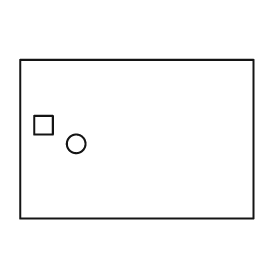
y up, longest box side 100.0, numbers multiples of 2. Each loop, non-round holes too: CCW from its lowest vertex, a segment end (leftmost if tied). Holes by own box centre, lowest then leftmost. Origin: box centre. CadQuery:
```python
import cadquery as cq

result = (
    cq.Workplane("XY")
    .moveTo(-50.0, -34.0)
    .lineTo(50.0, -34.0)
    .lineTo(50.0, 34.0)
    .lineTo(-50.0, 34.0)
    .close()
    .moveTo(-26.0, -2.0)
    .circle(4.0)
    .moveTo(-44.0, 2.0)
    .lineTo(-36.0, 2.0)
    .lineTo(-36.0, 10.0)
    .lineTo(-44.0, 10.0)
    .close()
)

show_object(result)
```